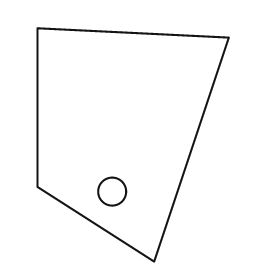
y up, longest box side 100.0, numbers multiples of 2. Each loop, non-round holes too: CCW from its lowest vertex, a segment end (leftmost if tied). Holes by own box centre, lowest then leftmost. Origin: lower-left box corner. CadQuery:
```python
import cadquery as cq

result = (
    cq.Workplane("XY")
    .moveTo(50.0, 0.0)
    .lineTo(82.0, 96.0)
    .lineTo(0.0, 100.0)
    .lineTo(0.0, 32.0)
    .close()
    .moveTo(32.0, 30.0)
    .circle(6.0)
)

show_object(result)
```